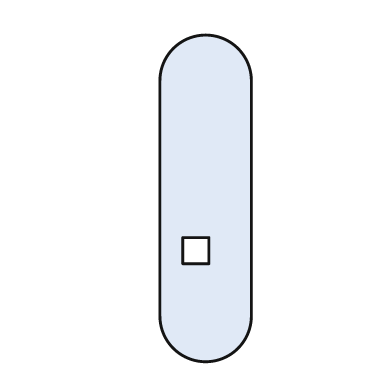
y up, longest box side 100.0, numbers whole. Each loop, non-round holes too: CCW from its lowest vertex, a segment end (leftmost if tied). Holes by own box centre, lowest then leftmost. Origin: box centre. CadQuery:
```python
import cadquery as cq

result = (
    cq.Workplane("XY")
    .moveTo(-14.0, -36.0)
    .threePointArc((0.0, -50.0), (14.0, -36.0))
    .lineTo(14.0, 36.0)
    .threePointArc((0.0, 50.0), (-14.0, 36.0))
    .close()
    .moveTo(-7.0, -20.0)
    .lineTo(1.0, -20.0)
    .lineTo(1.0, -12.0)
    .lineTo(-7.0, -12.0)
    .close()
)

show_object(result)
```